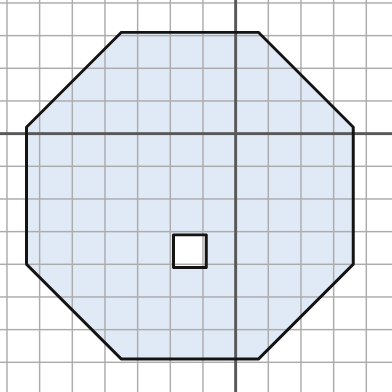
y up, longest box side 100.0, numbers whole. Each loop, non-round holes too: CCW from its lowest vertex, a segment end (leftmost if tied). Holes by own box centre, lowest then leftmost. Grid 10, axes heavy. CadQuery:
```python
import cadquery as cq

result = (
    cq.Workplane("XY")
    .moveTo(-35.0, -69.0)
    .lineTo(7.0, -69.0)
    .lineTo(36.0, -40.0)
    .lineTo(36.0, 2.0)
    .lineTo(7.0, 31.0)
    .lineTo(-35.0, 31.0)
    .lineTo(-64.0, 2.0)
    .lineTo(-64.0, -40.0)
    .close()
    .moveTo(-19.0, -41.0)
    .lineTo(-9.0, -41.0)
    .lineTo(-9.0, -31.0)
    .lineTo(-19.0, -31.0)
    .close()
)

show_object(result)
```